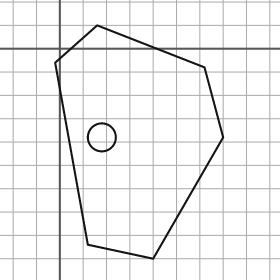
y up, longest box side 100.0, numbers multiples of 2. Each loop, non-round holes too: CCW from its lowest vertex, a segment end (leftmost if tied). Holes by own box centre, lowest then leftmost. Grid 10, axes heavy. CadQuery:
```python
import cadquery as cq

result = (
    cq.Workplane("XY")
    .moveTo(40.0, -90.0)
    .lineTo(70.0, -38.0)
    .lineTo(62.0, -8.0)
    .lineTo(16.0, 10.0)
    .lineTo(-2.0, -6.0)
    .lineTo(12.0, -84.0)
    .close()
    .moveTo(18.0, -38.0)
    .circle(6.0)
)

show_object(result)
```